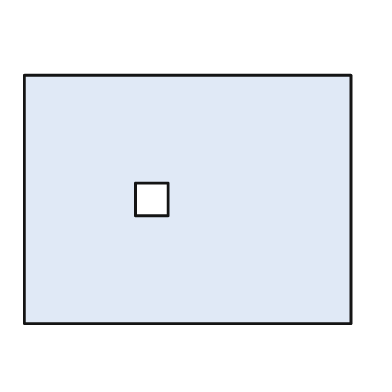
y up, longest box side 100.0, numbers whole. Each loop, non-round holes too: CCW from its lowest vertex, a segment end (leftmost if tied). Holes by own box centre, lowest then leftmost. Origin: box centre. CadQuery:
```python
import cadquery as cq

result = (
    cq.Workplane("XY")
    .moveTo(-50.0, -38.0)
    .lineTo(50.0, -38.0)
    .lineTo(50.0, 38.0)
    .lineTo(-50.0, 38.0)
    .close()
    .moveTo(-16.0, -5.0)
    .lineTo(-6.0, -5.0)
    .lineTo(-6.0, 5.0)
    .lineTo(-16.0, 5.0)
    .close()
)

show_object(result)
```